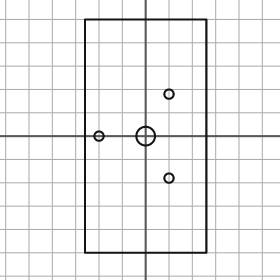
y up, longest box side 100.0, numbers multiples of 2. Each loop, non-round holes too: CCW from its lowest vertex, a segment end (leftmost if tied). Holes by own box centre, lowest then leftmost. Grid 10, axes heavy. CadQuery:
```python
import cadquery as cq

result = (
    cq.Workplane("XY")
    .moveTo(-26.0, -50.0)
    .lineTo(26.0, -50.0)
    .lineTo(26.0, 50.0)
    .lineTo(-26.0, 50.0)
    .close()
    .moveTo(10.0, -18.0)
    .circle(2.0)
    .moveTo(-20.0, 0.0)
    .circle(2.0)
    .moveTo(0.0, 0.0)
    .circle(4.0)
    .moveTo(10.0, 18.0)
    .circle(2.0)
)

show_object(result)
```